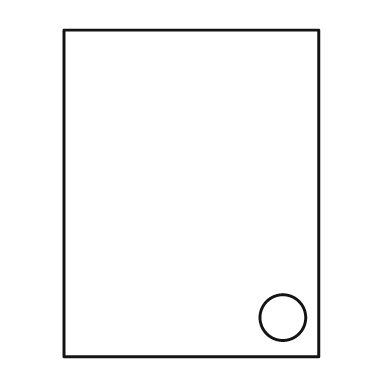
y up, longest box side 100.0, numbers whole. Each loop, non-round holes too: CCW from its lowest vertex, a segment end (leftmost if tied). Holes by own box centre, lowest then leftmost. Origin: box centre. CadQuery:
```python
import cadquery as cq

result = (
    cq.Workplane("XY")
    .moveTo(-39.0, -50.0)
    .lineTo(39.0, -50.0)
    .lineTo(39.0, 50.0)
    .lineTo(-39.0, 50.0)
    .close()
    .moveTo(28.0, -38.0)
    .circle(7.0)
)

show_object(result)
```